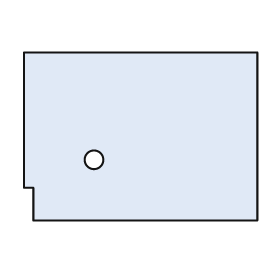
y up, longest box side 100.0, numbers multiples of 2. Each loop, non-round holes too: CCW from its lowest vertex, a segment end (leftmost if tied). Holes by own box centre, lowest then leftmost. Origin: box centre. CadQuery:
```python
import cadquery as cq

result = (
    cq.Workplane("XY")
    .moveTo(-46.0, -36.0)
    .lineTo(50.0, -36.0)
    .lineTo(50.0, 36.0)
    .lineTo(-50.0, 36.0)
    .lineTo(-50.0, -22.0)
    .lineTo(-46.0, -22.0)
    .close()
    .moveTo(-20.0, -10.0)
    .circle(4.0)
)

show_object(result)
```